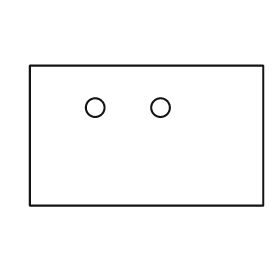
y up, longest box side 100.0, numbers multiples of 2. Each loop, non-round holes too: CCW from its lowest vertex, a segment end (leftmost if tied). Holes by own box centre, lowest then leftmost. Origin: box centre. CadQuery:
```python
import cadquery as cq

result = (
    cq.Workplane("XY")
    .moveTo(-50.0, -30.0)
    .lineTo(50.0, -30.0)
    .lineTo(50.0, 30.0)
    .lineTo(-50.0, 30.0)
    .close()
    .moveTo(-22.0, 12.0)
    .circle(4.0)
    .moveTo(6.0, 12.0)
    .circle(4.0)
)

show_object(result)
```